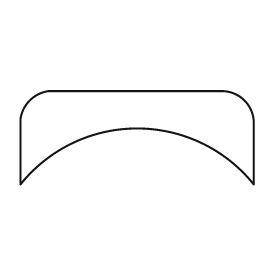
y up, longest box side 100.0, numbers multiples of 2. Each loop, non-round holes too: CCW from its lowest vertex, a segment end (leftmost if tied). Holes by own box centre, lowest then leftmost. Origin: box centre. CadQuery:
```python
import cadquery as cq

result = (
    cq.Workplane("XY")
    .moveTo(-50.0, -20.0)
    .threePointArc((0.0, 4.0), (50.0, -20.0))
    .lineTo(50.0, 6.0)
    .threePointArc((46.0, 16.0), (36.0, 20.0))
    .lineTo(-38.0, 20.0)
    .threePointArc((-46.0, 16.0), (-50.0, 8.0))
    .close()
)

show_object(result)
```